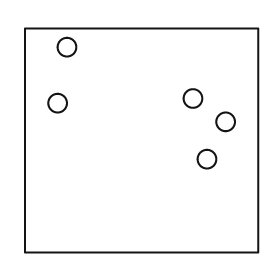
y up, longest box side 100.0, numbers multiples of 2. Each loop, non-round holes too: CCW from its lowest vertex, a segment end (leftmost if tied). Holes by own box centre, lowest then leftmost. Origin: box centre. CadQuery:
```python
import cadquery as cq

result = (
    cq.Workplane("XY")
    .moveTo(-50.0, -48.0)
    .lineTo(50.0, -48.0)
    .lineTo(50.0, 48.0)
    .lineTo(-50.0, 48.0)
    .close()
    .moveTo(28.0, -8.0)
    .circle(4.0)
    .moveTo(36.0, 8.0)
    .circle(4.0)
    .moveTo(-36.0, 16.0)
    .circle(4.0)
    .moveTo(22.0, 18.0)
    .circle(4.0)
    .moveTo(-32.0, 40.0)
    .circle(4.0)
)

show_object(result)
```